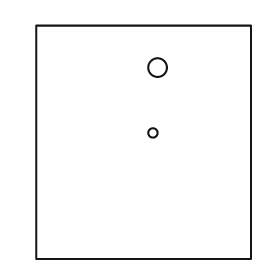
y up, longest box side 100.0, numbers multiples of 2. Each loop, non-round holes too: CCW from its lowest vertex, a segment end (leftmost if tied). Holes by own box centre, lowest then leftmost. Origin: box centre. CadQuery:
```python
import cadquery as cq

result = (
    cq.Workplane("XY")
    .moveTo(-46.0, -50.0)
    .lineTo(46.0, -50.0)
    .lineTo(46.0, 50.0)
    .lineTo(-46.0, 50.0)
    .close()
    .moveTo(4.0, 4.0)
    .circle(2.0)
    .moveTo(6.0, 32.0)
    .circle(4.0)
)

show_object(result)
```